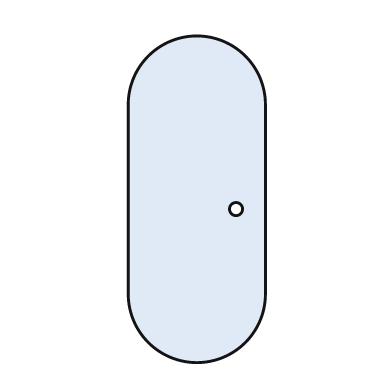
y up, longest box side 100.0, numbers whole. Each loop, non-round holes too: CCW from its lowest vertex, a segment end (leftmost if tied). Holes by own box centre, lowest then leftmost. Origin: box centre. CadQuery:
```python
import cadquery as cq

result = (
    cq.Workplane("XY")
    .moveTo(-21.0, -29.0)
    .threePointArc((0.0, -50.0), (21.0, -29.0))
    .lineTo(21.0, 29.0)
    .threePointArc((0.0, 50.0), (-21.0, 29.0))
    .close()
    .moveTo(12.0, -3.0)
    .circle(2.0)
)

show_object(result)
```